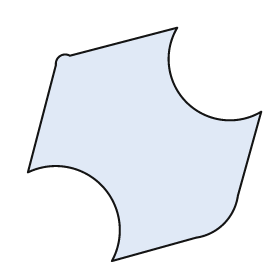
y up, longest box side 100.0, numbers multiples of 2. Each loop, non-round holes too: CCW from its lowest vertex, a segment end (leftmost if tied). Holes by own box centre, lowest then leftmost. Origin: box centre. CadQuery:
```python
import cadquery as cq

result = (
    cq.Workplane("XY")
    .moveTo(-14.0, -50.0)
    .lineTo(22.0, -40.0)
    .threePointArc((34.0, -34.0), (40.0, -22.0))
    .lineTo(50.0, 14.0)
    .threePointArc((18.0, 18.0), (14.0, 50.0))
    .lineTo(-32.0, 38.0)
    .threePointArc((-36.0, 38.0), (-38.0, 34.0))
    .lineTo(-50.0, -12.0)
    .threePointArc((-18.0, -18.0), (-14.0, -50.0))
    .close()
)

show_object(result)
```